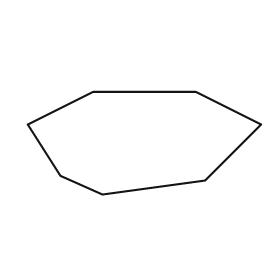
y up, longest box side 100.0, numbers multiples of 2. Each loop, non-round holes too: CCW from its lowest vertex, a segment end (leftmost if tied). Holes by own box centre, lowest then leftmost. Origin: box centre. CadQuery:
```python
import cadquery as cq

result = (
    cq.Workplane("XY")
    .moveTo(-18.0, -22.0)
    .lineTo(26.0, -16.0)
    .lineTo(50.0, 8.0)
    .lineTo(22.0, 22.0)
    .lineTo(-22.0, 22.0)
    .lineTo(-50.0, 8.0)
    .lineTo(-36.0, -14.0)
    .close()
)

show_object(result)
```